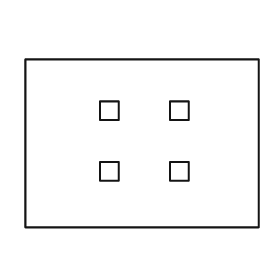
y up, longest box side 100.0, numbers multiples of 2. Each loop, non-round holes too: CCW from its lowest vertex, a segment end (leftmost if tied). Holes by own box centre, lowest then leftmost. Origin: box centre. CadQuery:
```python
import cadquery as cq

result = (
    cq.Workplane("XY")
    .moveTo(-50.0, -36.0)
    .lineTo(50.0, -36.0)
    .lineTo(50.0, 36.0)
    .lineTo(-50.0, 36.0)
    .close()
    .moveTo(-18.0, -16.0)
    .lineTo(-10.0, -16.0)
    .lineTo(-10.0, -8.0)
    .lineTo(-18.0, -8.0)
    .close()
    .moveTo(12.0, -16.0)
    .lineTo(20.0, -16.0)
    .lineTo(20.0, -8.0)
    .lineTo(12.0, -8.0)
    .close()
    .moveTo(-18.0, 10.0)
    .lineTo(-10.0, 10.0)
    .lineTo(-10.0, 18.0)
    .lineTo(-18.0, 18.0)
    .close()
    .moveTo(12.0, 10.0)
    .lineTo(20.0, 10.0)
    .lineTo(20.0, 18.0)
    .lineTo(12.0, 18.0)
    .close()
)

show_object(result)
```